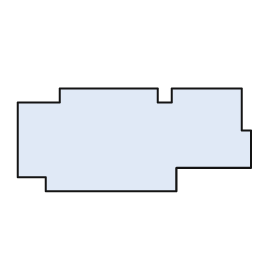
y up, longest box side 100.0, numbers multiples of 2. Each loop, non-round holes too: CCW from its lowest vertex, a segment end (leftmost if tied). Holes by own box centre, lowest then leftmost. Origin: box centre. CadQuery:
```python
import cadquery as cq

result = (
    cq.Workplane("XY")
    .moveTo(-38.0, -22.0)
    .lineTo(18.0, -22.0)
    .lineTo(18.0, -12.0)
    .lineTo(50.0, -12.0)
    .lineTo(50.0, 4.0)
    .lineTo(46.0, 4.0)
    .lineTo(46.0, 22.0)
    .lineTo(16.0, 22.0)
    .lineTo(16.0, 16.0)
    .lineTo(10.0, 16.0)
    .lineTo(10.0, 22.0)
    .lineTo(-32.0, 22.0)
    .lineTo(-32.0, 16.0)
    .lineTo(-50.0, 16.0)
    .lineTo(-50.0, -16.0)
    .lineTo(-38.0, -16.0)
    .close()
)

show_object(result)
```